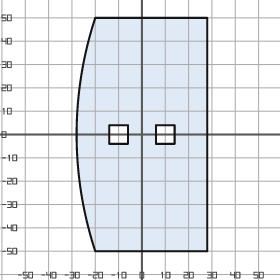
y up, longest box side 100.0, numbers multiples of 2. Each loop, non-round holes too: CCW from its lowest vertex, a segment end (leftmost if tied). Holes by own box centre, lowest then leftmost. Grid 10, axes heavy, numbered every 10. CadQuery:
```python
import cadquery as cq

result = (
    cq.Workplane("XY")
    .moveTo(-20.0, -50.0)
    .lineTo(28.0, -50.0)
    .lineTo(28.0, 50.0)
    .lineTo(-20.0, 50.0)
    .threePointArc((-28.0, 0.0), (-20.0, -50.0))
    .close()
    .moveTo(-14.0, -4.0)
    .lineTo(-6.0, -4.0)
    .lineTo(-6.0, 4.0)
    .lineTo(-14.0, 4.0)
    .close()
    .moveTo(6.0, -4.0)
    .lineTo(14.0, -4.0)
    .lineTo(14.0, 4.0)
    .lineTo(6.0, 4.0)
    .close()
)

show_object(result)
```